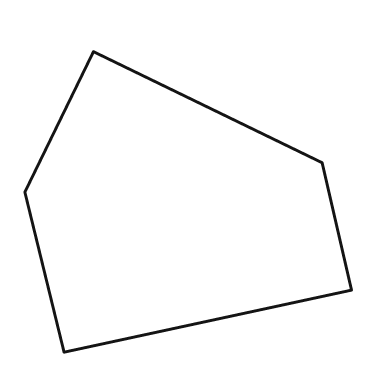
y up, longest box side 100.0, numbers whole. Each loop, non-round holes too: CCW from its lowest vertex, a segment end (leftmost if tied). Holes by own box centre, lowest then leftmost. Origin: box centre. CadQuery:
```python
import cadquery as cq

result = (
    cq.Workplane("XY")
    .moveTo(-38.0, -46.0)
    .lineTo(50.0, -27.0)
    .lineTo(41.0, 12.0)
    .lineTo(-29.0, 46.0)
    .lineTo(-50.0, 3.0)
    .close()
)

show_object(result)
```